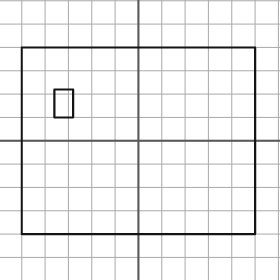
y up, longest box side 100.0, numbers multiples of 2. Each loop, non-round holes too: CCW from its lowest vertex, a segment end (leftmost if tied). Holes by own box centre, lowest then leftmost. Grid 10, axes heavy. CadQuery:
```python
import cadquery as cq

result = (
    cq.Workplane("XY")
    .moveTo(-50.0, -40.0)
    .lineTo(50.0, -40.0)
    .lineTo(50.0, 40.0)
    .lineTo(-50.0, 40.0)
    .close()
    .moveTo(-36.0, 10.0)
    .lineTo(-28.0, 10.0)
    .lineTo(-28.0, 22.0)
    .lineTo(-36.0, 22.0)
    .close()
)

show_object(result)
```